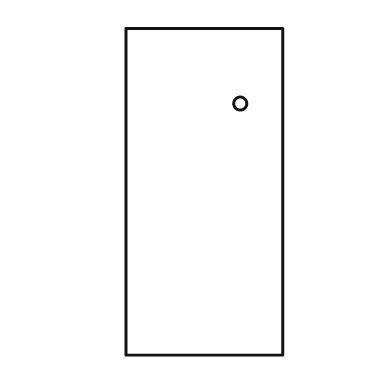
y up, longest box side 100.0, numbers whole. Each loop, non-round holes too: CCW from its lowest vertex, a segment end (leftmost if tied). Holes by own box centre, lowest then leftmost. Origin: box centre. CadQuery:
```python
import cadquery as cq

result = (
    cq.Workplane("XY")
    .moveTo(-24.0, -50.0)
    .lineTo(24.0, -50.0)
    .lineTo(24.0, 50.0)
    .lineTo(-24.0, 50.0)
    .close()
    .moveTo(11.0, 27.0)
    .circle(2.0)
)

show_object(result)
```